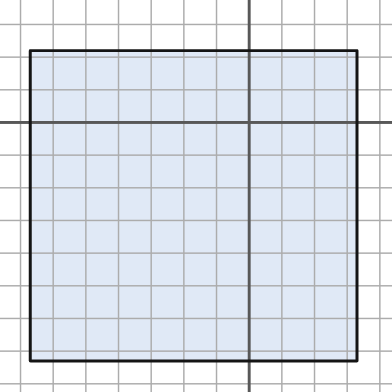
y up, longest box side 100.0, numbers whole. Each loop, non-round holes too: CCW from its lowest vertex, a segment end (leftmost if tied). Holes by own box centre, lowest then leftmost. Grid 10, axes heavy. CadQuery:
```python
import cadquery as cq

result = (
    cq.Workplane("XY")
    .moveTo(-67.0, -73.0)
    .lineTo(33.0, -73.0)
    .lineTo(33.0, 22.0)
    .lineTo(-67.0, 22.0)
    .close()
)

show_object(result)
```